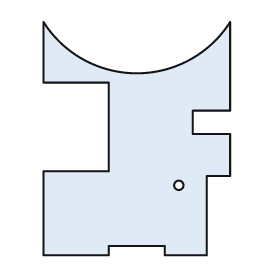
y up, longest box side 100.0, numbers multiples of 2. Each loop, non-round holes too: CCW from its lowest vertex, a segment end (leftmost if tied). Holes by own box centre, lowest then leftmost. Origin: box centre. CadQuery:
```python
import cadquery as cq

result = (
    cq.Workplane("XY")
    .moveTo(-40.0, -50.0)
    .lineTo(-12.0, -50.0)
    .lineTo(-12.0, -46.0)
    .lineTo(12.0, -46.0)
    .lineTo(12.0, -50.0)
    .lineTo(30.0, -50.0)
    .lineTo(30.0, -16.0)
    .lineTo(40.0, -16.0)
    .lineTo(40.0, 2.0)
    .lineTo(24.0, 2.0)
    .lineTo(24.0, 12.0)
    .lineTo(40.0, 12.0)
    .lineTo(40.0, 50.0)
    .threePointArc((0.0, 28.0), (-40.0, 50.0))
    .lineTo(-40.0, 24.0)
    .lineTo(-12.0, 24.0)
    .lineTo(-12.0, -14.0)
    .lineTo(-40.0, -14.0)
    .close()
    .moveTo(18.0, -20.0)
    .circle(2.0)
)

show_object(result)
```